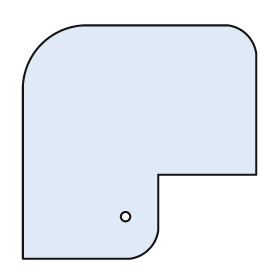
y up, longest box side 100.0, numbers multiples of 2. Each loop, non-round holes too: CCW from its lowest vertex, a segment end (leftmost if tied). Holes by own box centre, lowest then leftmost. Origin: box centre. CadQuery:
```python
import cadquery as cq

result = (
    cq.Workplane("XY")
    .moveTo(-50.0, -50.0)
    .lineTo(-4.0, -50.0)
    .threePointArc((4.0, -46.0), (8.0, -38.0))
    .lineTo(8.0, -14.0)
    .lineTo(50.0, -14.0)
    .lineTo(50.0, 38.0)
    .threePointArc((46.0, 46.0), (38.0, 50.0))
    .lineTo(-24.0, 50.0)
    .threePointArc((-42.0, 42.0), (-50.0, 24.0))
    .close()
    .moveTo(-6.0, -32.0)
    .circle(2.0)
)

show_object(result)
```